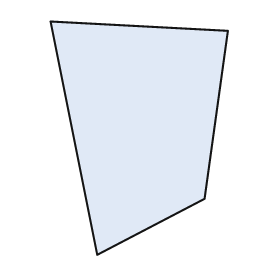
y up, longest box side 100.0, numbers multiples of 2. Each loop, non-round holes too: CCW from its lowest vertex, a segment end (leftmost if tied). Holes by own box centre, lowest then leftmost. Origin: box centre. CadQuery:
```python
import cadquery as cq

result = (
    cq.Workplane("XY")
    .moveTo(-18.0, -50.0)
    .lineTo(28.0, -26.0)
    .lineTo(38.0, 46.0)
    .lineTo(-38.0, 50.0)
    .close()
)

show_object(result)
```